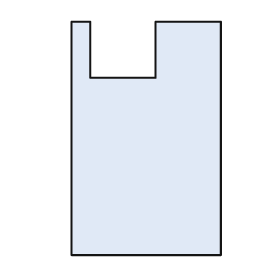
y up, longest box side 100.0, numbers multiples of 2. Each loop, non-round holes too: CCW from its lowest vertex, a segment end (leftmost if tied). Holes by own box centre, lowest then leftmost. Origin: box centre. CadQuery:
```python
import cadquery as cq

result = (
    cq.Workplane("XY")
    .moveTo(-32.0, -50.0)
    .lineTo(32.0, -50.0)
    .lineTo(32.0, 50.0)
    .lineTo(4.0, 50.0)
    .lineTo(4.0, 26.0)
    .lineTo(-24.0, 26.0)
    .lineTo(-24.0, 50.0)
    .lineTo(-32.0, 50.0)
    .close()
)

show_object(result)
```